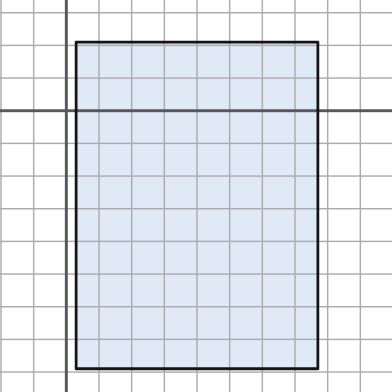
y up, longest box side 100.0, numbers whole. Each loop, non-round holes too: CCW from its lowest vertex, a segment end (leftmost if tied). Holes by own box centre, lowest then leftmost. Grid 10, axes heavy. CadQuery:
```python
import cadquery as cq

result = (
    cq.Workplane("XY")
    .moveTo(3.0, -79.0)
    .lineTo(77.0, -79.0)
    .lineTo(77.0, 21.0)
    .lineTo(3.0, 21.0)
    .close()
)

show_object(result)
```